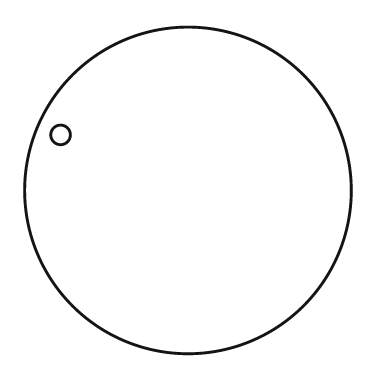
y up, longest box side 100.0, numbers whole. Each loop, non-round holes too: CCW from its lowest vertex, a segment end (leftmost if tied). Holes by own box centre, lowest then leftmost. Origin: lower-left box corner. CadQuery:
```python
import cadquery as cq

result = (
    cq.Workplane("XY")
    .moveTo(50.0, 50.0)
    .circle(50.0)
    .moveTo(11.0, 67.0)
    .circle(3.0)
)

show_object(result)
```